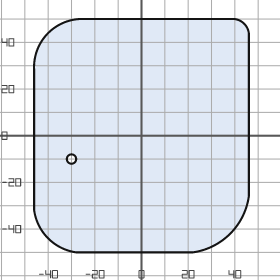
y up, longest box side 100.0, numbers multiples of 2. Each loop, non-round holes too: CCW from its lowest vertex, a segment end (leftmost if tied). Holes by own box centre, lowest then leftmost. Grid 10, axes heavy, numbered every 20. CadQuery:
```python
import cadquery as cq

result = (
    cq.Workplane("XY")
    .moveTo(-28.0, -50.0)
    .lineTo(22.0, -50.0)
    .threePointArc((38.0, -42.0), (46.0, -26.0))
    .lineTo(46.0, 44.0)
    .threePointArc((44.0, 48.0), (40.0, 50.0))
    .lineTo(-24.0, 50.0)
    .threePointArc((-40.0, 44.0), (-46.0, 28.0))
    .lineTo(-46.0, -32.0)
    .threePointArc((-40.0, -44.0), (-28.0, -50.0))
    .close()
    .moveTo(-30.0, -10.0)
    .circle(2.0)
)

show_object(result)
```